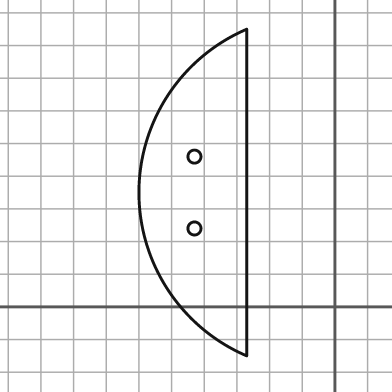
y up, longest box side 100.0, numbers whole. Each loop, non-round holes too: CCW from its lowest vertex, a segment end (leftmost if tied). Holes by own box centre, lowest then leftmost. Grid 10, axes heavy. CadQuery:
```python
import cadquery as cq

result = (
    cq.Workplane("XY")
    .moveTo(-27.0, -15.0)
    .lineTo(-27.0, 85.0)
    .threePointArc((-60.0, 35.0), (-27.0, -15.0))
    .close()
    .moveTo(-43.0, 24.0)
    .circle(2.0)
    .moveTo(-43.0, 46.0)
    .circle(2.0)
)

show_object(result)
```